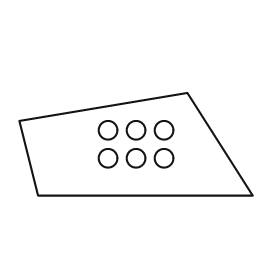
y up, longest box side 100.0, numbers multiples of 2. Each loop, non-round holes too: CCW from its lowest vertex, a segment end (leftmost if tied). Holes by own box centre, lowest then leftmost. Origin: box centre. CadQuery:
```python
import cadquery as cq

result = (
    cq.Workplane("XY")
    .moveTo(-42.0, -22.0)
    .lineTo(50.0, -22.0)
    .lineTo(22.0, 22.0)
    .lineTo(-50.0, 10.0)
    .close()
    .moveTo(-12.0, -6.0)
    .circle(4.0)
    .moveTo(0.0, -6.0)
    .circle(4.0)
    .moveTo(12.0, -6.0)
    .circle(4.0)
    .moveTo(-12.0, 6.0)
    .circle(4.0)
    .moveTo(0.0, 6.0)
    .circle(4.0)
    .moveTo(12.0, 6.0)
    .circle(4.0)
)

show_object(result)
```